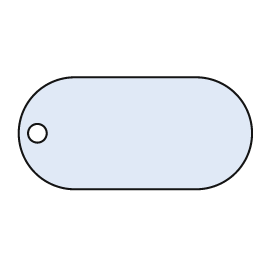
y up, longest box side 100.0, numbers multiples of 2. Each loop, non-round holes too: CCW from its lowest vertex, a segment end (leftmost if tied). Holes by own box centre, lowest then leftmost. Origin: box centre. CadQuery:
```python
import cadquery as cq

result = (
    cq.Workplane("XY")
    .moveTo(-26.0, -24.0)
    .lineTo(26.0, -24.0)
    .threePointArc((50.0, 0.0), (26.0, 24.0))
    .lineTo(-26.0, 24.0)
    .threePointArc((-50.0, 0.0), (-26.0, -24.0))
    .close()
    .moveTo(-42.0, 0.0)
    .circle(4.0)
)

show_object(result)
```